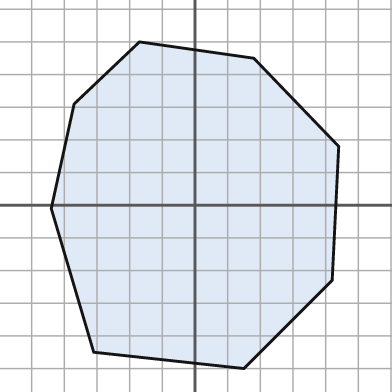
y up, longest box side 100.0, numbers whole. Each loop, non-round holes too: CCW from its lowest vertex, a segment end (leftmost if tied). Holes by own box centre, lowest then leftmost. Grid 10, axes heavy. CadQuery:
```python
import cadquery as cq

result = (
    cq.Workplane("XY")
    .moveTo(15.0, -50.0)
    .lineTo(42.0, -23.0)
    .lineTo(44.0, 18.0)
    .lineTo(18.0, 45.0)
    .lineTo(-17.0, 50.0)
    .lineTo(-37.0, 31.0)
    .lineTo(-44.0, -1.0)
    .lineTo(-31.0, -45.0)
    .close()
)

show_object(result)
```